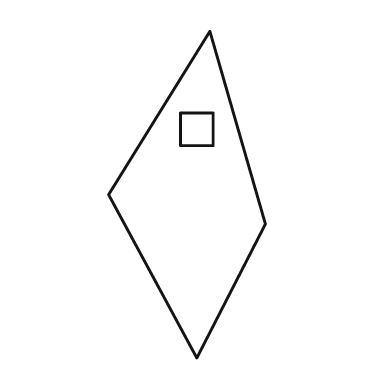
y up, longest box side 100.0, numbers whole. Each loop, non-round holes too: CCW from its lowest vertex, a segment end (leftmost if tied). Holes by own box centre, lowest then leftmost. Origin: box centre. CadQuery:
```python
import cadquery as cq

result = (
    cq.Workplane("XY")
    .moveTo(3.0, -50.0)
    .lineTo(24.0, -9.0)
    .lineTo(7.0, 50.0)
    .lineTo(-24.0, 0.0)
    .close()
    .moveTo(-2.0, 15.0)
    .lineTo(8.0, 15.0)
    .lineTo(8.0, 25.0)
    .lineTo(-2.0, 25.0)
    .close()
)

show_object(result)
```